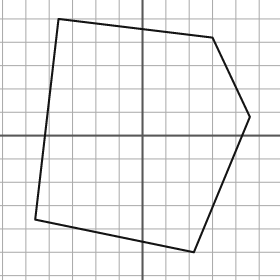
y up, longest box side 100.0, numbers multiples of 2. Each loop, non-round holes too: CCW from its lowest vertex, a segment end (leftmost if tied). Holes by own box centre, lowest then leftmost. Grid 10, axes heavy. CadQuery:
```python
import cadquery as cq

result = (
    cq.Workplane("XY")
    .moveTo(22.0, -50.0)
    .lineTo(46.0, 8.0)
    .lineTo(30.0, 42.0)
    .lineTo(-36.0, 50.0)
    .lineTo(-46.0, -36.0)
    .close()
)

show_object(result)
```